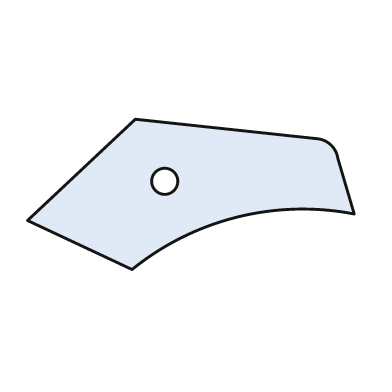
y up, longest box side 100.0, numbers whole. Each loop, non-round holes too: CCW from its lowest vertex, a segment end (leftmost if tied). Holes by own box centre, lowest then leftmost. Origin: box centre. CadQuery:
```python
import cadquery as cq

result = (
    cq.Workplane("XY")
    .moveTo(-18.0, -23.0)
    .threePointArc((14.0, -7.0), (50.0, -6.0))
    .lineTo(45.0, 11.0)
    .threePointArc((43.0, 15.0), (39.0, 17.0))
    .lineTo(-17.0, 23.0)
    .lineTo(-50.0, -8.0)
    .close()
    .moveTo(-8.0, 4.0)
    .circle(4.0)
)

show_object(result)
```